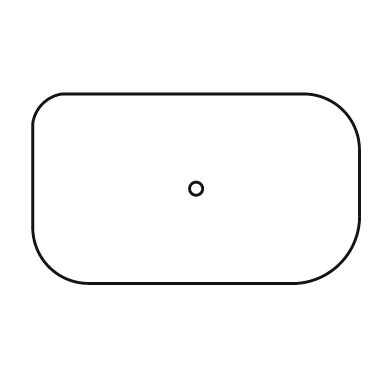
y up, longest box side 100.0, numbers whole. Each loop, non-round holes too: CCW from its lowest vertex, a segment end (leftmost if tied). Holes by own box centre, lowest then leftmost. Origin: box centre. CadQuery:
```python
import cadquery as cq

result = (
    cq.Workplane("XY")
    .moveTo(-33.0, -29.0)
    .lineTo(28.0, -29.0)
    .threePointArc((44.0, -23.0), (50.0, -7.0))
    .lineTo(50.0, 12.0)
    .threePointArc((45.0, 24.0), (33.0, 29.0))
    .lineTo(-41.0, 29.0)
    .threePointArc((-47.0, 26.0), (-50.0, 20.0))
    .lineTo(-50.0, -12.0)
    .threePointArc((-45.0, -24.0), (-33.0, -29.0))
    .close()
    .moveTo(0.0, 0.0)
    .circle(2.0)
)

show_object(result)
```